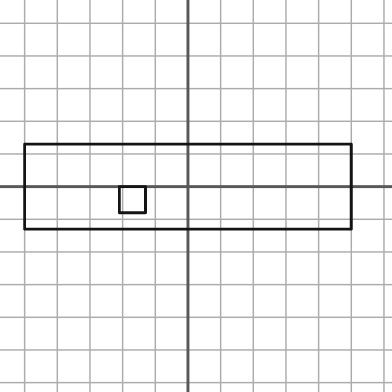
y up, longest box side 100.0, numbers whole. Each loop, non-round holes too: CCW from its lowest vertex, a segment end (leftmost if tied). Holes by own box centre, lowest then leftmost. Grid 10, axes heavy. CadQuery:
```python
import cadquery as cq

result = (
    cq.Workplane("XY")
    .moveTo(-50.0, -13.0)
    .lineTo(50.0, -13.0)
    .lineTo(50.0, 13.0)
    .lineTo(-50.0, 13.0)
    .close()
    .moveTo(-21.0, -8.0)
    .lineTo(-13.0, -8.0)
    .lineTo(-13.0, 0.0)
    .lineTo(-21.0, 0.0)
    .close()
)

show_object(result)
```